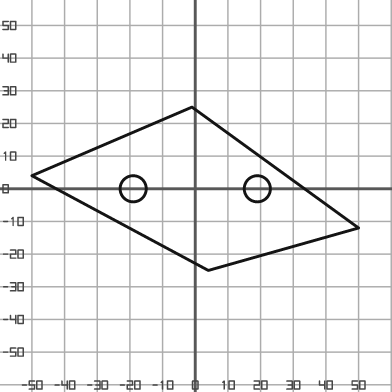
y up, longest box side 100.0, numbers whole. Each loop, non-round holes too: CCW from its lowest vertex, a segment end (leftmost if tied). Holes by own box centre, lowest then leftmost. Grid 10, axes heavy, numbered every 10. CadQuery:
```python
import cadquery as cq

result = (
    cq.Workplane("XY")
    .moveTo(4.0, -25.0)
    .lineTo(50.0, -12.0)
    .lineTo(-1.0, 25.0)
    .lineTo(-50.0, 4.0)
    .close()
    .moveTo(-19.0, 0.0)
    .circle(4.0)
    .moveTo(19.0, 0.0)
    .circle(4.0)
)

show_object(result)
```